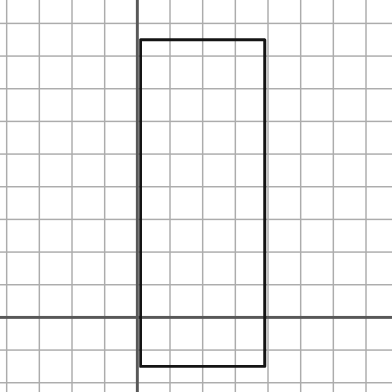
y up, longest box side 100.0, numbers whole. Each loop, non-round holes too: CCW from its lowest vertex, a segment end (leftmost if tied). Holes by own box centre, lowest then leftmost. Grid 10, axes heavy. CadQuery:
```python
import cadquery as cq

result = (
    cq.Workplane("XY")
    .moveTo(1.0, -15.0)
    .lineTo(39.0, -15.0)
    .lineTo(39.0, 85.0)
    .lineTo(1.0, 85.0)
    .close()
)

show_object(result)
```